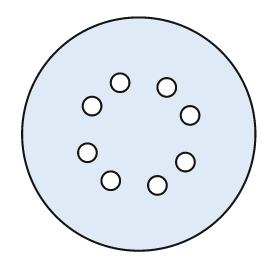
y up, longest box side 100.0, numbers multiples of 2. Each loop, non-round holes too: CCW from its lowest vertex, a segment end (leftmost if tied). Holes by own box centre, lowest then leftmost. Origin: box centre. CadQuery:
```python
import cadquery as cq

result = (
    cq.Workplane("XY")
    .moveTo(0.0, 0.0)
    .circle(50.0)
    .moveTo(8.0, -22.0)
    .circle(4.0)
    .moveTo(-12.0, -20.0)
    .circle(4.0)
    .moveTo(20.0, -12.0)
    .circle(4.0)
    .moveTo(-22.0, -8.0)
    .circle(4.0)
    .moveTo(22.0, 8.0)
    .circle(4.0)
    .moveTo(-20.0, 12.0)
    .circle(4.0)
    .moveTo(12.0, 20.0)
    .circle(4.0)
    .moveTo(-8.0, 22.0)
    .circle(4.0)
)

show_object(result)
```